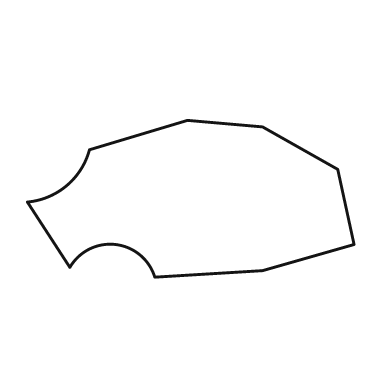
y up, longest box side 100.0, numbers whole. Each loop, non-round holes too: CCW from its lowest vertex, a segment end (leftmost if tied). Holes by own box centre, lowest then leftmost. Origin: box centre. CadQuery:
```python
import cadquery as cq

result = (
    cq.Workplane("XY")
    .moveTo(-11.0, -24.0)
    .lineTo(22.0, -22.0)
    .lineTo(50.0, -14.0)
    .lineTo(45.0, 9.0)
    .lineTo(22.0, 22.0)
    .lineTo(-1.0, 24.0)
    .lineTo(-31.0, 15.0)
    .threePointArc((-38.0, 4.0), (-50.0, -1.0))
    .lineTo(-37.0, -21.0)
    .threePointArc((-23.0, -14.0), (-11.0, -24.0))
    .close()
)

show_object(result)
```